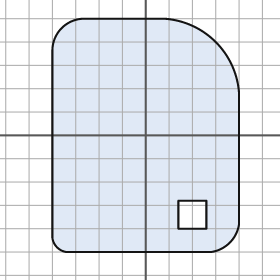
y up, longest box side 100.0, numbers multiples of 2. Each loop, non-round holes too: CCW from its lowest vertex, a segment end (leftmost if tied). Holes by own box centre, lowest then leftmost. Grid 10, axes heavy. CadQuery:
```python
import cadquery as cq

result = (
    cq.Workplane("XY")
    .moveTo(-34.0, -50.0)
    .lineTo(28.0, -50.0)
    .threePointArc((36.0, -46.0), (40.0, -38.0))
    .lineTo(40.0, 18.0)
    .threePointArc((30.0, 40.0), (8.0, 50.0))
    .lineTo(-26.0, 50.0)
    .threePointArc((-36.0, 46.0), (-40.0, 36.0))
    .lineTo(-40.0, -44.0)
    .threePointArc((-38.0, -48.0), (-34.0, -50.0))
    .close()
    .moveTo(14.0, -40.0)
    .lineTo(26.0, -40.0)
    .lineTo(26.0, -28.0)
    .lineTo(14.0, -28.0)
    .close()
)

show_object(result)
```